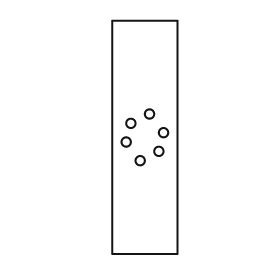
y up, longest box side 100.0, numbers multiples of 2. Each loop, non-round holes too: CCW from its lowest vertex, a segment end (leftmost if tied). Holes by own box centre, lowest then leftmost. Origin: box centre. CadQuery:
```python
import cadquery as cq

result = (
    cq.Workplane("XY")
    .moveTo(-14.0, -50.0)
    .lineTo(14.0, -50.0)
    .lineTo(14.0, 50.0)
    .lineTo(-14.0, 50.0)
    .close()
    .moveTo(-2.0, -10.0)
    .circle(2.0)
    .moveTo(6.0, -6.0)
    .circle(2.0)
    .moveTo(-8.0, -2.0)
    .circle(2.0)
    .moveTo(8.0, 2.0)
    .circle(2.0)
    .moveTo(-6.0, 6.0)
    .circle(2.0)
    .moveTo(2.0, 10.0)
    .circle(2.0)
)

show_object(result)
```